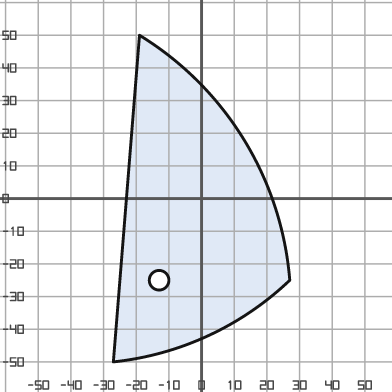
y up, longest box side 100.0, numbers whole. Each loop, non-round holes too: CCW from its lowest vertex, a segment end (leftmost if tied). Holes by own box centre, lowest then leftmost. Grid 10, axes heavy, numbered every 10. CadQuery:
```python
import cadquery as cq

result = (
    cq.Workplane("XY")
    .moveTo(-27.0, -50.0)
    .threePointArc((2.0, -42.0), (27.0, -25.0))
    .threePointArc((13.0, 18.0), (-19.0, 50.0))
    .close()
    .moveTo(-13.0, -25.0)
    .circle(3.0)
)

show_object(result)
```